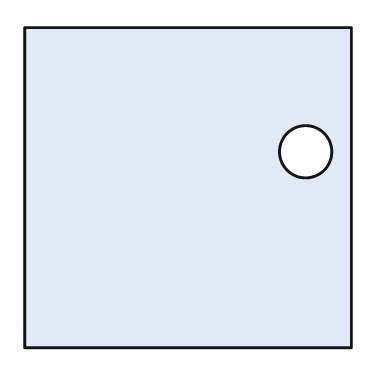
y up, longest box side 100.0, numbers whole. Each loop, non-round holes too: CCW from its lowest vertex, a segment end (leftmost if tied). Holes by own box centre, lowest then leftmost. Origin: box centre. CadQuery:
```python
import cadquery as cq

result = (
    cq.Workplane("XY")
    .moveTo(-50.0, -49.0)
    .lineTo(50.0, -49.0)
    .lineTo(50.0, 49.0)
    .lineTo(-50.0, 49.0)
    .close()
    .moveTo(36.0, 11.0)
    .circle(8.0)
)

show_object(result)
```